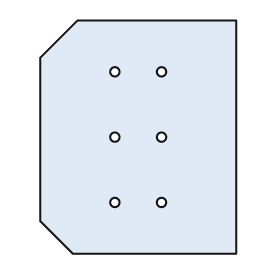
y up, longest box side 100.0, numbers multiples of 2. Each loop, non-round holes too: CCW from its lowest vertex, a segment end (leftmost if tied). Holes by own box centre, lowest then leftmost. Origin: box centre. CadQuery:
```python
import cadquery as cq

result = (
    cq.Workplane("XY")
    .moveTo(-28.0, -50.0)
    .lineTo(42.0, -50.0)
    .lineTo(42.0, 50.0)
    .lineTo(-26.0, 50.0)
    .lineTo(-42.0, 34.0)
    .lineTo(-42.0, -36.0)
    .close()
    .moveTo(-10.0, -28.0)
    .circle(2.0)
    .moveTo(10.0, -28.0)
    .circle(2.0)
    .moveTo(-10.0, 0.0)
    .circle(2.0)
    .moveTo(10.0, 0.0)
    .circle(2.0)
    .moveTo(-10.0, 28.0)
    .circle(2.0)
    .moveTo(10.0, 28.0)
    .circle(2.0)
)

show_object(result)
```